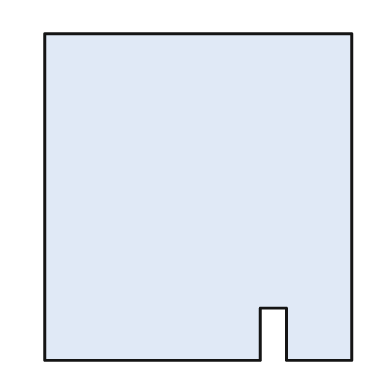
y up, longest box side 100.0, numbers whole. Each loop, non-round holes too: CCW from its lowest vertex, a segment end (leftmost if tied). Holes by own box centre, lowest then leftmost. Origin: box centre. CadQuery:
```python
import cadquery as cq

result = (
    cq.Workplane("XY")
    .moveTo(-47.0, -50.0)
    .lineTo(19.0, -50.0)
    .lineTo(19.0, -34.0)
    .lineTo(27.0, -34.0)
    .lineTo(27.0, -50.0)
    .lineTo(47.0, -50.0)
    .lineTo(47.0, 50.0)
    .lineTo(-47.0, 50.0)
    .close()
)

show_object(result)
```